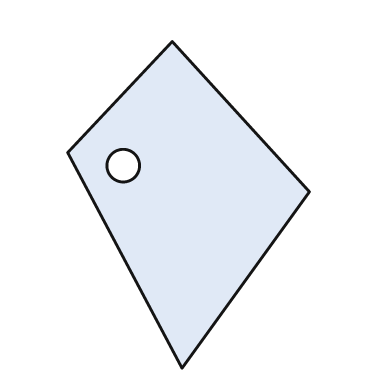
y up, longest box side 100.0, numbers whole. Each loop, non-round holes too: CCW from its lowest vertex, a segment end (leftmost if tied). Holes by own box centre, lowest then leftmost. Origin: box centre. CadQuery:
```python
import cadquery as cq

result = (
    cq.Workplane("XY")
    .moveTo(-2.0, -50.0)
    .lineTo(37.0, 4.0)
    .lineTo(-5.0, 50.0)
    .lineTo(-37.0, 16.0)
    .close()
    .moveTo(-20.0, 12.0)
    .circle(5.0)
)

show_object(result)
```